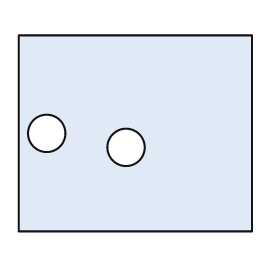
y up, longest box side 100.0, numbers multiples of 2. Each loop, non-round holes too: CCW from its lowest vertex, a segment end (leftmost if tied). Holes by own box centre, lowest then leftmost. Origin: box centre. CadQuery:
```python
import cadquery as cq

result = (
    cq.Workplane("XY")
    .moveTo(-50.0, -42.0)
    .lineTo(50.0, -42.0)
    .lineTo(50.0, 42.0)
    .lineTo(-50.0, 42.0)
    .close()
    .moveTo(-4.0, -6.0)
    .circle(8.0)
    .moveTo(-38.0, 0.0)
    .circle(8.0)
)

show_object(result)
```